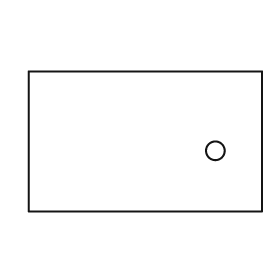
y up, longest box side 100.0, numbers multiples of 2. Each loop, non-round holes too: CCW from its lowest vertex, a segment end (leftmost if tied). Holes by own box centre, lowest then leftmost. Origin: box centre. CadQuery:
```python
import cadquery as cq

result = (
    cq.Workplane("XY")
    .moveTo(-50.0, -30.0)
    .lineTo(50.0, -30.0)
    .lineTo(50.0, 30.0)
    .lineTo(-50.0, 30.0)
    .close()
    .moveTo(30.0, -4.0)
    .circle(4.0)
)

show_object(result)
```